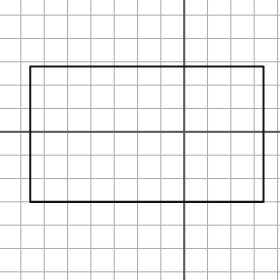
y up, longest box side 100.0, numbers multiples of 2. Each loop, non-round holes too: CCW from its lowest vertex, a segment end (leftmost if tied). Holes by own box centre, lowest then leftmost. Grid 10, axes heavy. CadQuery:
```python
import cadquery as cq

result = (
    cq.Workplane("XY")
    .moveTo(-66.0, -30.0)
    .lineTo(34.0, -30.0)
    .lineTo(34.0, 28.0)
    .lineTo(-66.0, 28.0)
    .close()
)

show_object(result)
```